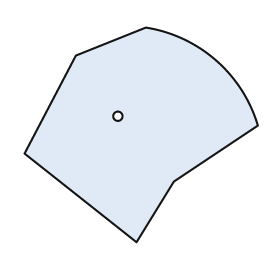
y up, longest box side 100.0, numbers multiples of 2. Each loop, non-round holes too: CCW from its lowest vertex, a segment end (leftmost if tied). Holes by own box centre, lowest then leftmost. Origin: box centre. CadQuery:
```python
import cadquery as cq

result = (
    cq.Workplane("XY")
    .moveTo(-2.0, -46.0)
    .lineTo(14.0, -20.0)
    .lineTo(50.0, 4.0)
    .threePointArc((32.0, 32.0), (2.0, 46.0))
    .lineTo(-28.0, 34.0)
    .lineTo(-50.0, -8.0)
    .close()
    .moveTo(-10.0, 8.0)
    .circle(2.0)
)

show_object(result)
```